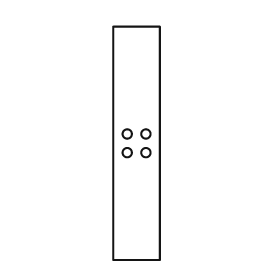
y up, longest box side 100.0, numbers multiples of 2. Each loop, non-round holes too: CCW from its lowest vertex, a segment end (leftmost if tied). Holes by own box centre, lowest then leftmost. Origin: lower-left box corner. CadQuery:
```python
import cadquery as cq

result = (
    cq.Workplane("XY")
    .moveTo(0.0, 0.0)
    .lineTo(20.0, 0.0)
    .lineTo(20.0, 100.0)
    .lineTo(0.0, 100.0)
    .close()
    .moveTo(6.0, 46.0)
    .circle(2.0)
    .moveTo(14.0, 46.0)
    .circle(2.0)
    .moveTo(6.0, 54.0)
    .circle(2.0)
    .moveTo(14.0, 54.0)
    .circle(2.0)
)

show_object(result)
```